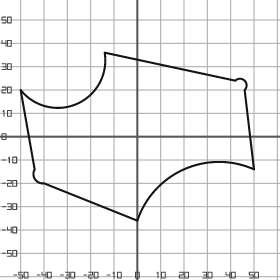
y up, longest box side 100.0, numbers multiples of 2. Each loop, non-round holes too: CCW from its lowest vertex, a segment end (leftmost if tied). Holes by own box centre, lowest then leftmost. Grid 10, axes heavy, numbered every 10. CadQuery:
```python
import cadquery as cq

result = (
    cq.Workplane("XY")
    .moveTo(0.0, -36.0)
    .threePointArc((20.0, -14.0), (50.0, -14.0))
    .lineTo(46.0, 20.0)
    .threePointArc((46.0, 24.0), (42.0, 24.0))
    .lineTo(-14.0, 36.0)
    .threePointArc((-26.0, 14.0), (-50.0, 20.0))
    .lineTo(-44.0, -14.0)
    .threePointArc((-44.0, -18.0), (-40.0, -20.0))
    .close()
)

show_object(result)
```